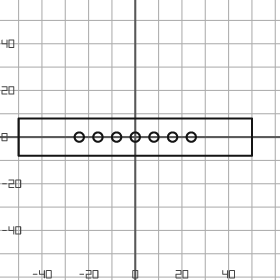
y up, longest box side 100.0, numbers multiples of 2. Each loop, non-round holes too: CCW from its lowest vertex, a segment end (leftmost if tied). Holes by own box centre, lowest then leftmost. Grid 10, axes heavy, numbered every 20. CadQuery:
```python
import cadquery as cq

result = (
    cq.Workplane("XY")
    .moveTo(-50.0, -8.0)
    .lineTo(50.0, -8.0)
    .lineTo(50.0, 8.0)
    .lineTo(-50.0, 8.0)
    .close()
    .moveTo(-24.0, 0.0)
    .circle(2.0)
    .moveTo(-16.0, 0.0)
    .circle(2.0)
    .moveTo(-8.0, 0.0)
    .circle(2.0)
    .moveTo(0.0, 0.0)
    .circle(2.0)
    .moveTo(8.0, 0.0)
    .circle(2.0)
    .moveTo(16.0, 0.0)
    .circle(2.0)
    .moveTo(24.0, 0.0)
    .circle(2.0)
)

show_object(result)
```